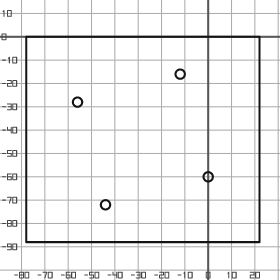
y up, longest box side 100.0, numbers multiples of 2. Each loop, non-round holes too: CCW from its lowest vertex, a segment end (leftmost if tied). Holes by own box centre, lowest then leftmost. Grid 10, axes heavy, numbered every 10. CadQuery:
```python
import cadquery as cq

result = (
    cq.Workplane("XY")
    .moveTo(-78.0, -88.0)
    .lineTo(22.0, -88.0)
    .lineTo(22.0, 0.0)
    .lineTo(-78.0, 0.0)
    .close()
    .moveTo(-44.0, -72.0)
    .circle(2.0)
    .moveTo(0.0, -60.0)
    .circle(2.0)
    .moveTo(-56.0, -28.0)
    .circle(2.0)
    .moveTo(-12.0, -16.0)
    .circle(2.0)
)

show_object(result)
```